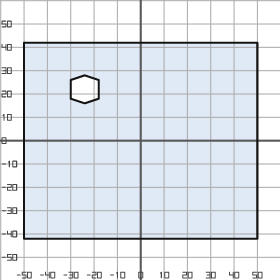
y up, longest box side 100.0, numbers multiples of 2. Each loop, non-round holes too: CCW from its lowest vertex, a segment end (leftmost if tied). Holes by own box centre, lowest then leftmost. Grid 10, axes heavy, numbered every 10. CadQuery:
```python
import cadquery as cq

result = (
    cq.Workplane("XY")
    .moveTo(-50.0, -42.0)
    .lineTo(50.0, -42.0)
    .lineTo(50.0, 42.0)
    .lineTo(-50.0, 42.0)
    .close()
    .moveTo(-24.0, 16.0)
    .lineTo(-18.0, 18.0)
    .lineTo(-18.0, 26.0)
    .lineTo(-24.0, 28.0)
    .lineTo(-30.0, 26.0)
    .lineTo(-30.0, 18.0)
    .close()
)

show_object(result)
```